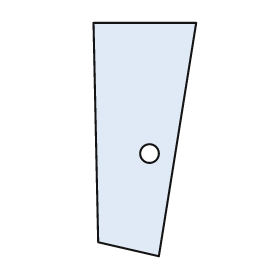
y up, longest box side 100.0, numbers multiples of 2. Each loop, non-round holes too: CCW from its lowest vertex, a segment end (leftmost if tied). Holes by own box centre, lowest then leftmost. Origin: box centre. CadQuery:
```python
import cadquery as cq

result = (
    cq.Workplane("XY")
    .moveTo(6.0, -50.0)
    .lineTo(22.0, 50.0)
    .lineTo(-22.0, 50.0)
    .lineTo(-20.0, -44.0)
    .close()
    .moveTo(2.0, -6.0)
    .circle(4.0)
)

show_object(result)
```